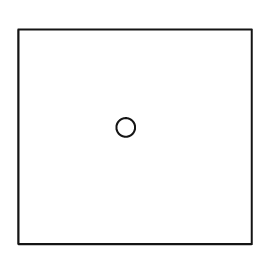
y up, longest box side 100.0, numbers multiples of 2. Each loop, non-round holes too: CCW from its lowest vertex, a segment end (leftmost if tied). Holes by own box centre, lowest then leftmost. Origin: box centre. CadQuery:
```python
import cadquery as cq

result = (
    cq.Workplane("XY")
    .moveTo(-50.0, -46.0)
    .lineTo(50.0, -46.0)
    .lineTo(50.0, 46.0)
    .lineTo(-50.0, 46.0)
    .close()
    .moveTo(-4.0, 4.0)
    .circle(4.0)
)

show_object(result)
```